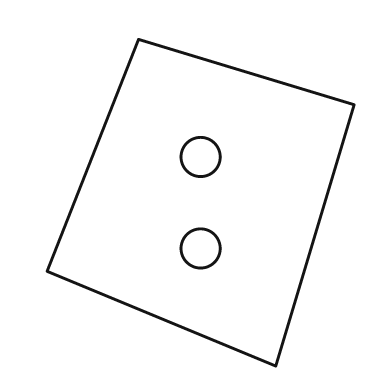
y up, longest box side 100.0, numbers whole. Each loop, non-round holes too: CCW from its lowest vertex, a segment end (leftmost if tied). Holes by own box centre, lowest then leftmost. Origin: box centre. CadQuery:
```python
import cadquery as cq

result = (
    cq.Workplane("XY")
    .moveTo(23.0, -50.0)
    .lineTo(47.0, 30.0)
    .lineTo(-19.0, 50.0)
    .lineTo(-47.0, -21.0)
    .close()
    .moveTo(0.0, -14.0)
    .circle(6.0)
    .moveTo(0.0, 14.0)
    .circle(6.0)
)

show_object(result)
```